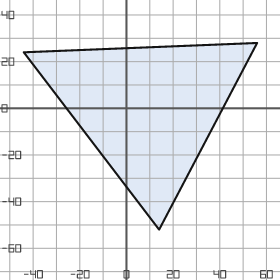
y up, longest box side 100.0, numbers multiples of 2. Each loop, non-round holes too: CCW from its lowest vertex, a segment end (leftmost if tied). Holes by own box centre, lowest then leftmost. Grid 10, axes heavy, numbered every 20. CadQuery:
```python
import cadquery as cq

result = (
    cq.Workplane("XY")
    .moveTo(14.0, -52.0)
    .lineTo(56.0, 28.0)
    .lineTo(-44.0, 24.0)
    .close()
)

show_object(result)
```